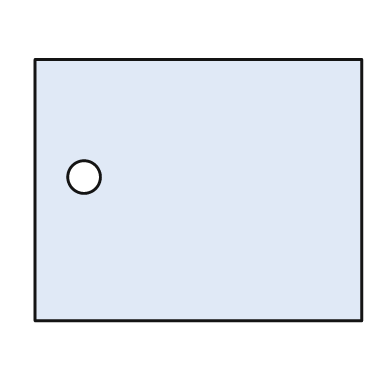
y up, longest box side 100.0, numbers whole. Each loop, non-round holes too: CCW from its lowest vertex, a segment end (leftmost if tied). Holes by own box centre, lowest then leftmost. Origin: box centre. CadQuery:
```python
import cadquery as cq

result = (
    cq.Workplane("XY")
    .moveTo(-50.0, -40.0)
    .lineTo(50.0, -40.0)
    .lineTo(50.0, 40.0)
    .lineTo(-50.0, 40.0)
    .close()
    .moveTo(-35.0, 4.0)
    .circle(5.0)
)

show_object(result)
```